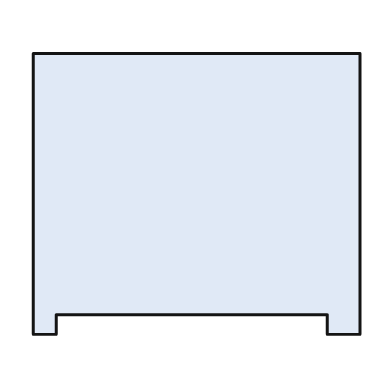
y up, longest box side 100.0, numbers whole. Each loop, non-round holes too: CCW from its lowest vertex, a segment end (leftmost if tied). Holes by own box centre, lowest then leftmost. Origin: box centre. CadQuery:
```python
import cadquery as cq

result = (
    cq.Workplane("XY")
    .moveTo(-50.0, -43.0)
    .lineTo(-43.0, -43.0)
    .lineTo(-43.0, -37.0)
    .lineTo(40.0, -37.0)
    .lineTo(40.0, -43.0)
    .lineTo(50.0, -43.0)
    .lineTo(50.0, 43.0)
    .lineTo(-50.0, 43.0)
    .close()
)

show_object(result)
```